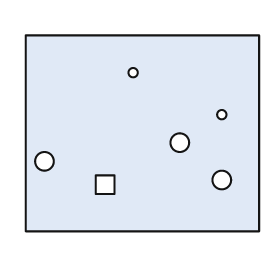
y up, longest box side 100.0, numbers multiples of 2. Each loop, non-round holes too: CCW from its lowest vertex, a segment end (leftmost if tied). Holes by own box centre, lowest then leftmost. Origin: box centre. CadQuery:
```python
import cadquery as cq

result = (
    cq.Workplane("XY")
    .moveTo(-50.0, -42.0)
    .lineTo(50.0, -42.0)
    .lineTo(50.0, 42.0)
    .lineTo(-50.0, 42.0)
    .close()
    .moveTo(-20.0, -26.0)
    .lineTo(-12.0, -26.0)
    .lineTo(-12.0, -18.0)
    .lineTo(-20.0, -18.0)
    .close()
    .moveTo(34.0, -20.0)
    .circle(4.0)
    .moveTo(-42.0, -12.0)
    .circle(4.0)
    .moveTo(16.0, -4.0)
    .circle(4.0)
    .moveTo(34.0, 8.0)
    .circle(2.0)
    .moveTo(-4.0, 26.0)
    .circle(2.0)
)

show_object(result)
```